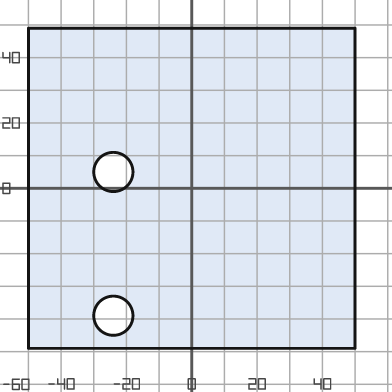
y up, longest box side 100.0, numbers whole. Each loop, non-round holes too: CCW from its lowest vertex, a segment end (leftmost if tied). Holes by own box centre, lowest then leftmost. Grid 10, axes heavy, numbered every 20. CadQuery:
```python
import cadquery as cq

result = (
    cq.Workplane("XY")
    .moveTo(-50.0, -49.0)
    .lineTo(50.0, -49.0)
    .lineTo(50.0, 49.0)
    .lineTo(-50.0, 49.0)
    .close()
    .moveTo(-24.0, -39.0)
    .circle(6.0)
    .moveTo(-24.0, 5.0)
    .circle(6.0)
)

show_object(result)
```